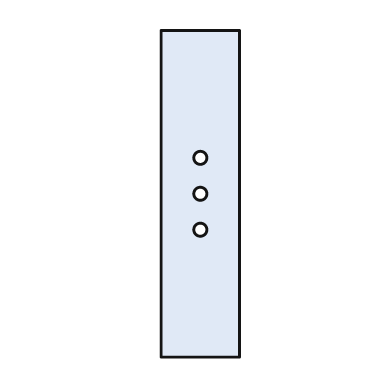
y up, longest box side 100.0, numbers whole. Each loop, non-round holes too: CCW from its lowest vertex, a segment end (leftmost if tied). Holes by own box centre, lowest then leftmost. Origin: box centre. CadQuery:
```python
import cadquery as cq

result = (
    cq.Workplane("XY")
    .moveTo(-12.0, -50.0)
    .lineTo(12.0, -50.0)
    .lineTo(12.0, 50.0)
    .lineTo(-12.0, 50.0)
    .close()
    .moveTo(0.0, -11.0)
    .circle(2.0)
    .moveTo(0.0, 0.0)
    .circle(2.0)
    .moveTo(0.0, 11.0)
    .circle(2.0)
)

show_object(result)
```